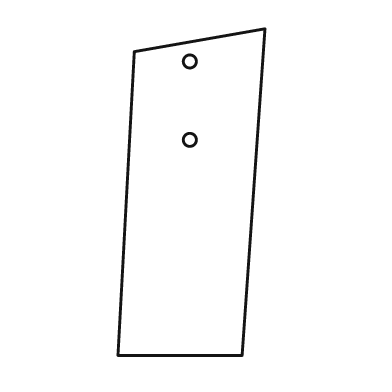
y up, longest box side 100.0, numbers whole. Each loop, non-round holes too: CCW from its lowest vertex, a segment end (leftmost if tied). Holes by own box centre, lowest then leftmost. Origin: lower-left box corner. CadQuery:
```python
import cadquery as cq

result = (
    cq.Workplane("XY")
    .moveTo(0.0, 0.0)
    .lineTo(38.0, 0.0)
    .lineTo(45.0, 100.0)
    .lineTo(5.0, 93.0)
    .close()
    .moveTo(22.0, 66.0)
    .circle(2.0)
    .moveTo(22.0, 90.0)
    .circle(2.0)
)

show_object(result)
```